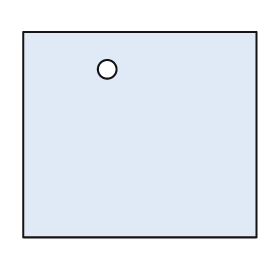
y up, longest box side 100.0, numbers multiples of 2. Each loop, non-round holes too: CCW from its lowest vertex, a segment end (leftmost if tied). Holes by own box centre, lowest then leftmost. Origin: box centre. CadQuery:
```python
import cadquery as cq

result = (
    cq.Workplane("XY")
    .moveTo(-50.0, -44.0)
    .lineTo(50.0, -44.0)
    .lineTo(50.0, 44.0)
    .lineTo(-50.0, 44.0)
    .close()
    .moveTo(-14.0, 28.0)
    .circle(4.0)
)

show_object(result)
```